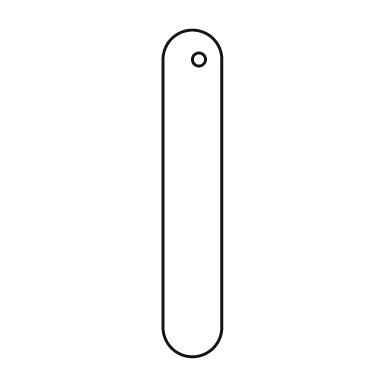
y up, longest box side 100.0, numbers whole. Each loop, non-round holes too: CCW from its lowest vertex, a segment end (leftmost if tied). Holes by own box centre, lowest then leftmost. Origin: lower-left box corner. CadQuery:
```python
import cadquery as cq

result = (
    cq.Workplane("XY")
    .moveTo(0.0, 9.0)
    .threePointArc((9.0, 0.0), (18.0, 9.0))
    .lineTo(18.0, 91.0)
    .threePointArc((9.0, 100.0), (0.0, 91.0))
    .close()
    .moveTo(11.0, 91.0)
    .circle(2.0)
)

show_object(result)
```